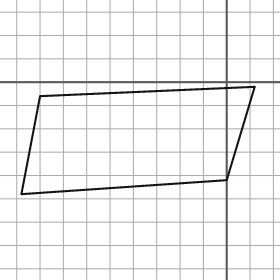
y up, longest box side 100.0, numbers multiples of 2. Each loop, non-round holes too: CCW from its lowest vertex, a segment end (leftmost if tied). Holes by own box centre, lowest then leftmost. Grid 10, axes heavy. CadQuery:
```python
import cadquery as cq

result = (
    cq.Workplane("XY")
    .moveTo(-88.0, -48.0)
    .lineTo(0.0, -42.0)
    .lineTo(12.0, -2.0)
    .lineTo(-80.0, -6.0)
    .close()
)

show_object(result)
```